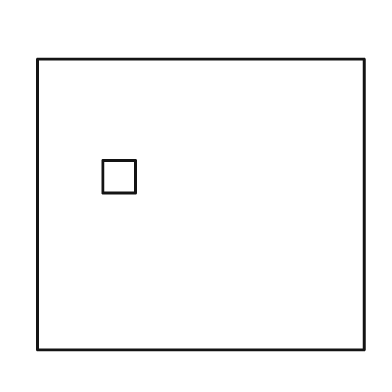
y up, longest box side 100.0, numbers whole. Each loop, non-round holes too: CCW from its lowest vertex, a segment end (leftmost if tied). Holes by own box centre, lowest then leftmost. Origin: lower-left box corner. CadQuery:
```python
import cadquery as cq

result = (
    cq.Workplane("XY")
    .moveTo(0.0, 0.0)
    .lineTo(100.0, 0.0)
    .lineTo(100.0, 89.0)
    .lineTo(0.0, 89.0)
    .close()
    .moveTo(20.0, 48.0)
    .lineTo(30.0, 48.0)
    .lineTo(30.0, 58.0)
    .lineTo(20.0, 58.0)
    .close()
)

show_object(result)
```